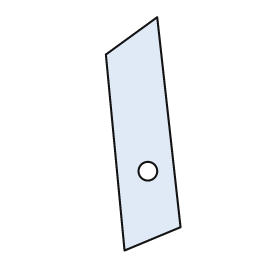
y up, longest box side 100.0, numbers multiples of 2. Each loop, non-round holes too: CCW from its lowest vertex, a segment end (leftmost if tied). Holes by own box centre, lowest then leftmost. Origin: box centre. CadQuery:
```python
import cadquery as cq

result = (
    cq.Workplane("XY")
    .moveTo(-8.0, -50.0)
    .lineTo(16.0, -40.0)
    .lineTo(6.0, 50.0)
    .lineTo(-16.0, 34.0)
    .close()
    .moveTo(2.0, -16.0)
    .circle(4.0)
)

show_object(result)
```